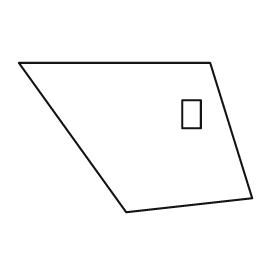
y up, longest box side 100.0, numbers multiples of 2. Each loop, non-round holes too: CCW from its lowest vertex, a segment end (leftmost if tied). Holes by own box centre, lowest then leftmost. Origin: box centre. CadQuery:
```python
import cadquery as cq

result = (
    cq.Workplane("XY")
    .moveTo(-4.0, -32.0)
    .lineTo(50.0, -26.0)
    .lineTo(32.0, 32.0)
    .lineTo(-50.0, 32.0)
    .close()
    .moveTo(20.0, 4.0)
    .lineTo(28.0, 4.0)
    .lineTo(28.0, 16.0)
    .lineTo(20.0, 16.0)
    .close()
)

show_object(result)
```